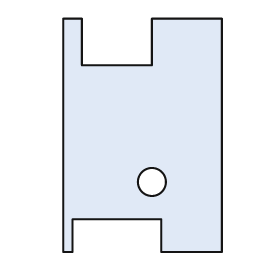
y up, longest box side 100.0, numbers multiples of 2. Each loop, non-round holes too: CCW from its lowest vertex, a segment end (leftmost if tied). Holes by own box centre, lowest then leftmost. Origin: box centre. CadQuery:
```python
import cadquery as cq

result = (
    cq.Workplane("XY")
    .moveTo(-34.0, -50.0)
    .lineTo(-30.0, -50.0)
    .lineTo(-30.0, -36.0)
    .lineTo(8.0, -36.0)
    .lineTo(8.0, -50.0)
    .lineTo(34.0, -50.0)
    .lineTo(34.0, 50.0)
    .lineTo(4.0, 50.0)
    .lineTo(4.0, 30.0)
    .lineTo(-26.0, 30.0)
    .lineTo(-26.0, 50.0)
    .lineTo(-34.0, 50.0)
    .close()
    .moveTo(4.0, -20.0)
    .circle(6.0)
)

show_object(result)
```